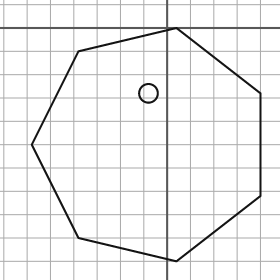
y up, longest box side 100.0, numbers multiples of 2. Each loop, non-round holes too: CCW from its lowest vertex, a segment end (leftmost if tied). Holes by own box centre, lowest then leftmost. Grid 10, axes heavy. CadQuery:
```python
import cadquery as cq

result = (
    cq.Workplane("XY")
    .moveTo(4.0, -100.0)
    .lineTo(40.0, -72.0)
    .lineTo(40.0, -28.0)
    .lineTo(4.0, 0.0)
    .lineTo(-38.0, -10.0)
    .lineTo(-58.0, -50.0)
    .lineTo(-38.0, -90.0)
    .close()
    .moveTo(-8.0, -28.0)
    .circle(4.0)
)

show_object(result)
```